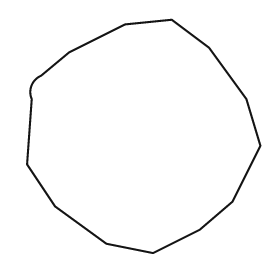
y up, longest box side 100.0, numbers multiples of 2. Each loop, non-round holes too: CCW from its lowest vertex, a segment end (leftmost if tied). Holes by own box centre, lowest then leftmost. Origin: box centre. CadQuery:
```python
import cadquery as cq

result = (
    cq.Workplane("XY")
    .moveTo(4.0, -50.0)
    .lineTo(24.0, -40.0)
    .lineTo(38.0, -28.0)
    .lineTo(50.0, -4.0)
    .lineTo(44.0, 16.0)
    .lineTo(28.0, 38.0)
    .lineTo(12.0, 50.0)
    .lineTo(-8.0, 48.0)
    .lineTo(-32.0, 36.0)
    .lineTo(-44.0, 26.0)
    .threePointArc((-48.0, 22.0), (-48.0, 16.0))
    .lineTo(-50.0, -12.0)
    .lineTo(-38.0, -30.0)
    .lineTo(-16.0, -46.0)
    .close()
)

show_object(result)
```